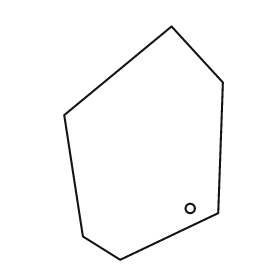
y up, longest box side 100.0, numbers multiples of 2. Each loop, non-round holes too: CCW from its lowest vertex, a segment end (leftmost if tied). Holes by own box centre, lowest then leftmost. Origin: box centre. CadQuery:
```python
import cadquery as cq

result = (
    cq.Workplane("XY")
    .moveTo(-10.0, -50.0)
    .lineTo(32.0, -30.0)
    .lineTo(34.0, 26.0)
    .lineTo(12.0, 50.0)
    .lineTo(-34.0, 12.0)
    .lineTo(-26.0, -40.0)
    .close()
    .moveTo(20.0, -28.0)
    .circle(2.0)
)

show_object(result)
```